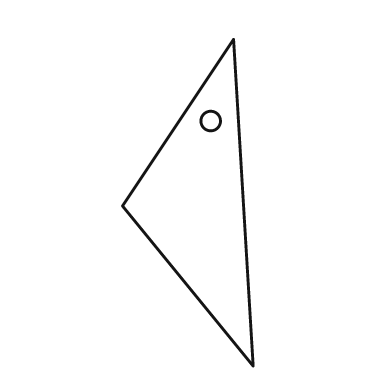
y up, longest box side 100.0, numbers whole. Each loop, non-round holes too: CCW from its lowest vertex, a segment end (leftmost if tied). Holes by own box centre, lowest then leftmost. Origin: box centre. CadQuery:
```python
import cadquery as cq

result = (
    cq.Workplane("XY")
    .moveTo(20.0, -50.0)
    .lineTo(14.0, 50.0)
    .lineTo(-20.0, -1.0)
    .close()
    .moveTo(7.0, 25.0)
    .circle(3.0)
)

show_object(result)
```